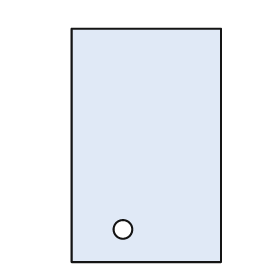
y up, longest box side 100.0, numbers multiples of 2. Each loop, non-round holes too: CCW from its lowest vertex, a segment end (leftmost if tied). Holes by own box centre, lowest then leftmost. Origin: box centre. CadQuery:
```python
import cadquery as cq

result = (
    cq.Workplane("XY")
    .moveTo(-32.0, -50.0)
    .lineTo(32.0, -50.0)
    .lineTo(32.0, 50.0)
    .lineTo(-32.0, 50.0)
    .close()
    .moveTo(-10.0, -36.0)
    .circle(4.0)
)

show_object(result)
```